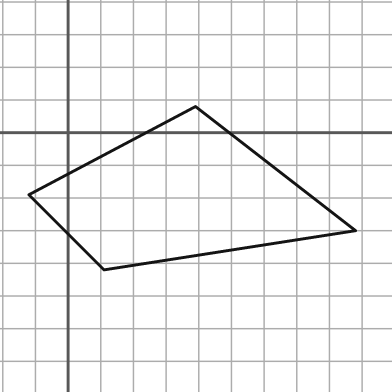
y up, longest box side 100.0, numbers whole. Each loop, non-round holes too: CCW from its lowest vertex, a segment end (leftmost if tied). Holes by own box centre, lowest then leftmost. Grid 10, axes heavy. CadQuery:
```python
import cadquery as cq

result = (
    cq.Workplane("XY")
    .moveTo(11.0, -42.0)
    .lineTo(88.0, -30.0)
    .lineTo(39.0, 8.0)
    .lineTo(-12.0, -19.0)
    .close()
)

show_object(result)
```